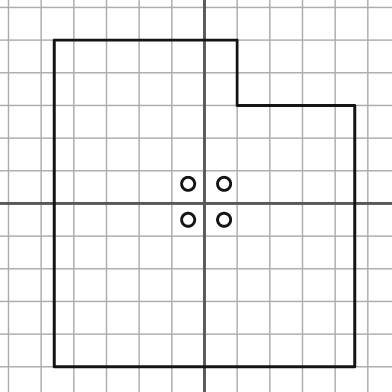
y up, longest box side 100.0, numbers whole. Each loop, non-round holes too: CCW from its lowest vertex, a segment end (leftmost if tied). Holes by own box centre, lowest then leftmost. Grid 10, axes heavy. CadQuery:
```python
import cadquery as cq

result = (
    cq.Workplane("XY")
    .moveTo(-46.0, -50.0)
    .lineTo(46.0, -50.0)
    .lineTo(46.0, 30.0)
    .lineTo(10.0, 30.0)
    .lineTo(10.0, 50.0)
    .lineTo(-46.0, 50.0)
    .close()
    .moveTo(-5.0, -5.0)
    .circle(2.0)
    .moveTo(6.0, -5.0)
    .circle(2.0)
    .moveTo(-5.0, 6.0)
    .circle(2.0)
    .moveTo(6.0, 6.0)
    .circle(2.0)
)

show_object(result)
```